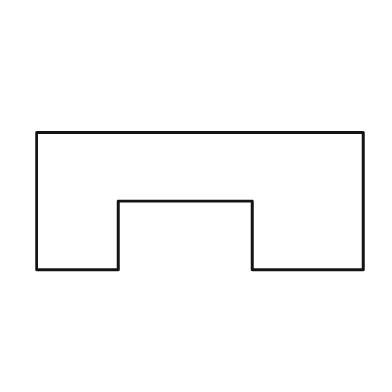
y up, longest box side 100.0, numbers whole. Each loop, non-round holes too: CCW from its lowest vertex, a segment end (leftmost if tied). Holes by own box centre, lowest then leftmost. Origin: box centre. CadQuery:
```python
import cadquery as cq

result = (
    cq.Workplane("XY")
    .moveTo(-50.0, -21.0)
    .lineTo(-25.0, -21.0)
    .lineTo(-25.0, 0.0)
    .lineTo(16.0, 0.0)
    .lineTo(16.0, -21.0)
    .lineTo(50.0, -21.0)
    .lineTo(50.0, 21.0)
    .lineTo(-50.0, 21.0)
    .close()
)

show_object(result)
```